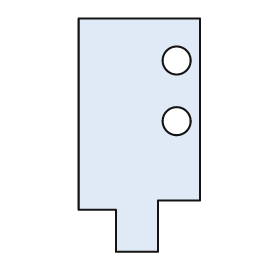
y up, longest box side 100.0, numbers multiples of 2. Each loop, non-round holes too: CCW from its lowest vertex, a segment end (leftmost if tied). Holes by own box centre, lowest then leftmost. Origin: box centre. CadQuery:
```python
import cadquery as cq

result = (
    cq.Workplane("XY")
    .moveTo(-10.0, -50.0)
    .lineTo(8.0, -50.0)
    .lineTo(8.0, -28.0)
    .lineTo(26.0, -28.0)
    .lineTo(26.0, 50.0)
    .lineTo(-26.0, 50.0)
    .lineTo(-26.0, -32.0)
    .lineTo(-10.0, -32.0)
    .close()
    .moveTo(16.0, 6.0)
    .circle(6.0)
    .moveTo(16.0, 32.0)
    .circle(6.0)
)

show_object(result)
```